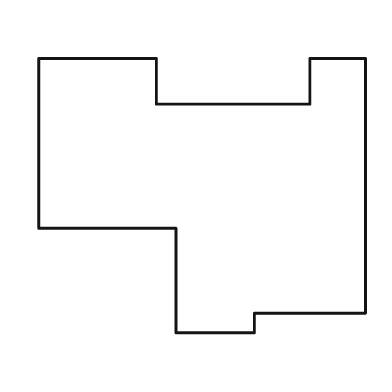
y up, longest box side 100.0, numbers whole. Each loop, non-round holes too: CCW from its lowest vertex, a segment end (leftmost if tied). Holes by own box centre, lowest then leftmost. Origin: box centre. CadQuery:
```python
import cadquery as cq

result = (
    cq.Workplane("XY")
    .moveTo(-8.0, -42.0)
    .lineTo(16.0, -42.0)
    .lineTo(16.0, -36.0)
    .lineTo(50.0, -36.0)
    .lineTo(50.0, 42.0)
    .lineTo(33.0, 42.0)
    .lineTo(33.0, 28.0)
    .lineTo(-14.0, 28.0)
    .lineTo(-14.0, 42.0)
    .lineTo(-50.0, 42.0)
    .lineTo(-50.0, -10.0)
    .lineTo(-8.0, -10.0)
    .close()
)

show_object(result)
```